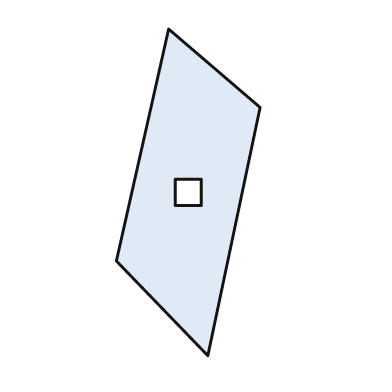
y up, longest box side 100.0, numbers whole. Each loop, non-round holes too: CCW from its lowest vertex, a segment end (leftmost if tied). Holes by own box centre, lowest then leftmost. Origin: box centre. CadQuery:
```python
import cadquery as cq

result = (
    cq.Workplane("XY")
    .moveTo(6.0, -50.0)
    .lineTo(22.0, 26.0)
    .lineTo(-6.0, 50.0)
    .lineTo(-22.0, -21.0)
    .close()
    .moveTo(-4.0, -4.0)
    .lineTo(4.0, -4.0)
    .lineTo(4.0, 4.0)
    .lineTo(-4.0, 4.0)
    .close()
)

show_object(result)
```